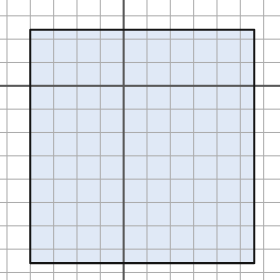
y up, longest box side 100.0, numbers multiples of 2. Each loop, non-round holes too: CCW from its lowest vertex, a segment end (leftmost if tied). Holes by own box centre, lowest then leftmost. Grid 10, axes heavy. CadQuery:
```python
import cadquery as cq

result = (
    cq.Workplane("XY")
    .moveTo(-40.0, -76.0)
    .lineTo(56.0, -76.0)
    .lineTo(56.0, 24.0)
    .lineTo(-40.0, 24.0)
    .close()
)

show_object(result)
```